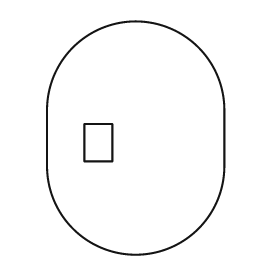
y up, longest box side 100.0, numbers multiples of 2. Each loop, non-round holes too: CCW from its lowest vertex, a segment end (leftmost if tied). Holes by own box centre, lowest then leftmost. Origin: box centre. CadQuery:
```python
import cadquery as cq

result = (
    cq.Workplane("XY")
    .moveTo(-38.0, -12.0)
    .threePointArc((0.0, -50.0), (38.0, -12.0))
    .lineTo(38.0, 12.0)
    .threePointArc((0.0, 50.0), (-38.0, 12.0))
    .close()
    .moveTo(-22.0, -10.0)
    .lineTo(-10.0, -10.0)
    .lineTo(-10.0, 6.0)
    .lineTo(-22.0, 6.0)
    .close()
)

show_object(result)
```